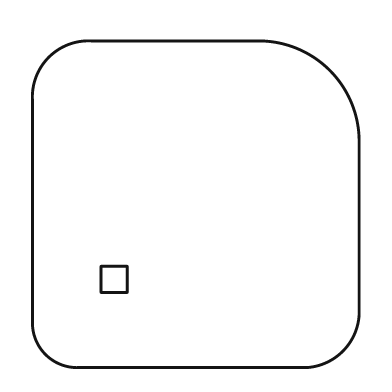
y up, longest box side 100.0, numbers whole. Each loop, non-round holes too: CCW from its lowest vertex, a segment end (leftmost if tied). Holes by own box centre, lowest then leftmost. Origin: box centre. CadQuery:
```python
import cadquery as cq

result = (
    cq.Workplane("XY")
    .moveTo(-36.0, -50.0)
    .lineTo(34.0, -50.0)
    .threePointArc((45.0, -45.0), (50.0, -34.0))
    .lineTo(50.0, 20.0)
    .threePointArc((41.0, 41.0), (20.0, 50.0))
    .lineTo(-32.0, 50.0)
    .threePointArc((-45.0, 45.0), (-50.0, 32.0))
    .lineTo(-50.0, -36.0)
    .threePointArc((-46.0, -46.0), (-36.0, -50.0))
    .close()
    .moveTo(-29.0, -27.0)
    .lineTo(-21.0, -27.0)
    .lineTo(-21.0, -19.0)
    .lineTo(-29.0, -19.0)
    .close()
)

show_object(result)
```